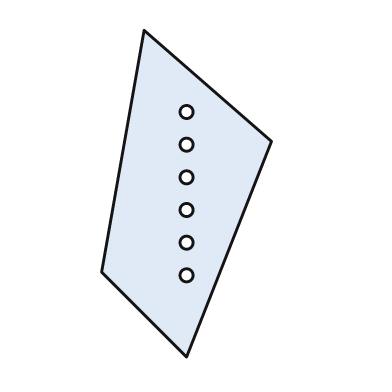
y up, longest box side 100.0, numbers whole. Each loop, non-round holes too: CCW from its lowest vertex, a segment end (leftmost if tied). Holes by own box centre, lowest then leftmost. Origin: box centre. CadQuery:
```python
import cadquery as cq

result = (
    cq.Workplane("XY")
    .moveTo(0.0, -50.0)
    .lineTo(26.0, 16.0)
    .lineTo(-13.0, 50.0)
    .lineTo(-26.0, -24.0)
    .close()
    .moveTo(0.0, -25.0)
    .circle(2.0)
    .moveTo(0.0, -15.0)
    .circle(2.0)
    .moveTo(0.0, -5.0)
    .circle(2.0)
    .moveTo(0.0, 5.0)
    .circle(2.0)
    .moveTo(0.0, 15.0)
    .circle(2.0)
    .moveTo(0.0, 25.0)
    .circle(2.0)
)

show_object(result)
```